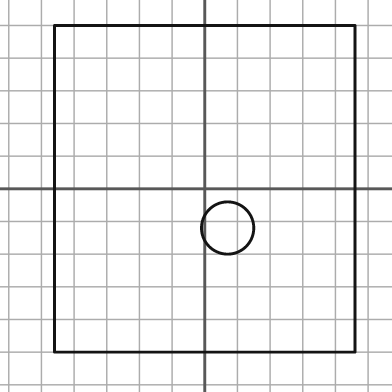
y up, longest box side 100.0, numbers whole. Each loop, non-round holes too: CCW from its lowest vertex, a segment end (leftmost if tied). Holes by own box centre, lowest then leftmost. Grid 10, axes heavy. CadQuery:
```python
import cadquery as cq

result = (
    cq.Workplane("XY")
    .moveTo(-46.0, -50.0)
    .lineTo(46.0, -50.0)
    .lineTo(46.0, 50.0)
    .lineTo(-46.0, 50.0)
    .close()
    .moveTo(7.0, -12.0)
    .circle(8.0)
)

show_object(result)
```